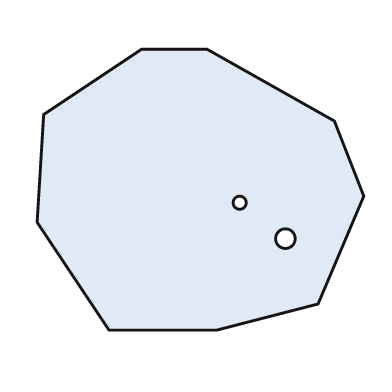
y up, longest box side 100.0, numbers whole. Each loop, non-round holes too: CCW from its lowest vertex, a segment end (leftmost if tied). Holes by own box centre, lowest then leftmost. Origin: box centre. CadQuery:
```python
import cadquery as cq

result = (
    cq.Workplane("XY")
    .moveTo(-28.0, -43.0)
    .lineTo(5.0, -43.0)
    .lineTo(36.0, -35.0)
    .lineTo(50.0, -2.0)
    .lineTo(41.0, 21.0)
    .lineTo(2.0, 43.0)
    .lineTo(-18.0, 43.0)
    .lineTo(-48.0, 23.0)
    .lineTo(-50.0, -10.0)
    .close()
    .moveTo(26.0, -15.0)
    .circle(3.0)
    .moveTo(12.0, -4.0)
    .circle(2.0)
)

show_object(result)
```